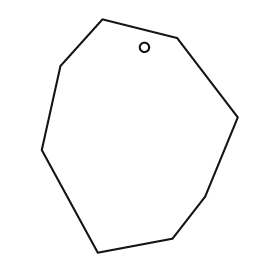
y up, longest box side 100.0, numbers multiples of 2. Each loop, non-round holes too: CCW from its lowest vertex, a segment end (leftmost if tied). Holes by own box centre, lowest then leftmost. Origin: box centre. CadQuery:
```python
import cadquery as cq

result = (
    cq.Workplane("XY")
    .moveTo(-18.0, -50.0)
    .lineTo(14.0, -44.0)
    .lineTo(28.0, -26.0)
    .lineTo(42.0, 8.0)
    .lineTo(16.0, 42.0)
    .lineTo(-16.0, 50.0)
    .lineTo(-34.0, 30.0)
    .lineTo(-42.0, -6.0)
    .close()
    .moveTo(2.0, 38.0)
    .circle(2.0)
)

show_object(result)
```